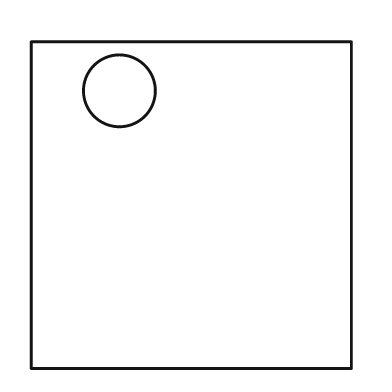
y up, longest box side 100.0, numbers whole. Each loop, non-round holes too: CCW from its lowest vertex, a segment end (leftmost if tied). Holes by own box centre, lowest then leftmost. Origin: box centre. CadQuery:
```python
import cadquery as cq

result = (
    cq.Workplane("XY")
    .moveTo(-49.0, -50.0)
    .lineTo(49.0, -50.0)
    .lineTo(49.0, 50.0)
    .lineTo(-49.0, 50.0)
    .close()
    .moveTo(-22.0, 35.0)
    .circle(11.0)
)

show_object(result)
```